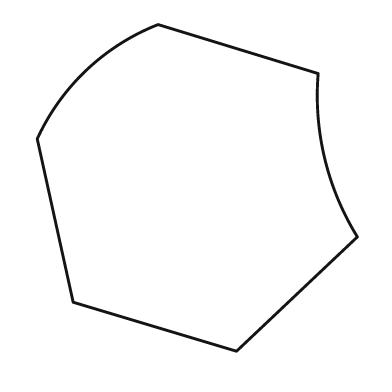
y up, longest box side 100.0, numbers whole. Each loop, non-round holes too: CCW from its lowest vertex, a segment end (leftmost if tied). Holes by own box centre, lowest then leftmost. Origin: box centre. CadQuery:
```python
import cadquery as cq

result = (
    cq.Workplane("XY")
    .moveTo(12.0, -50.0)
    .lineTo(49.0, -15.0)
    .threePointArc((39.0, 9.0), (37.0, 35.0))
    .lineTo(-12.0, 50.0)
    .threePointArc((-34.0, 36.0), (-49.0, 15.0))
    .lineTo(-38.0, -35.0)
    .close()
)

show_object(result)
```